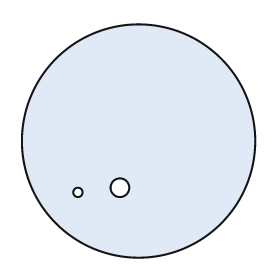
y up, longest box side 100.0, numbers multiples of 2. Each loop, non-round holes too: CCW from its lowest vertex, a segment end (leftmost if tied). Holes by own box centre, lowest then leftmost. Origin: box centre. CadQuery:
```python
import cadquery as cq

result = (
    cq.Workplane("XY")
    .moveTo(0.0, 0.0)
    .circle(50.0)
    .moveTo(-26.0, -22.0)
    .circle(2.0)
    .moveTo(-8.0, -20.0)
    .circle(4.0)
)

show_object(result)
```